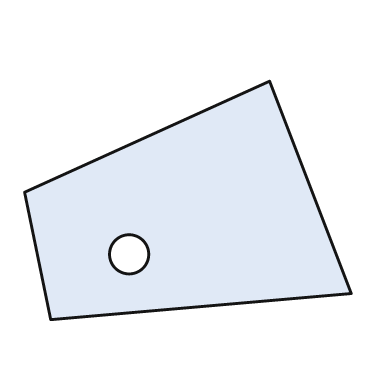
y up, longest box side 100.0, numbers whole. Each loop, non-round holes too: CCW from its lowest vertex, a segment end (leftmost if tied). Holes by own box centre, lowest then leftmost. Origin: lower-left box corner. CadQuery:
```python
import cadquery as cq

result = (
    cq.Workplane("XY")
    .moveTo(8.0, 0.0)
    .lineTo(100.0, 8.0)
    .lineTo(75.0, 73.0)
    .lineTo(0.0, 39.0)
    .close()
    .moveTo(32.0, 20.0)
    .circle(6.0)
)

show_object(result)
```